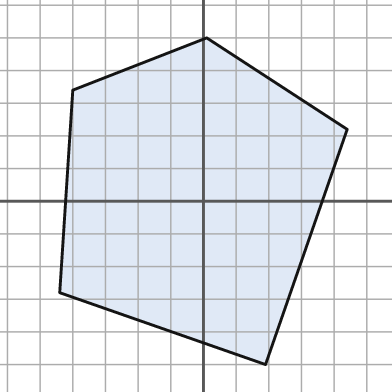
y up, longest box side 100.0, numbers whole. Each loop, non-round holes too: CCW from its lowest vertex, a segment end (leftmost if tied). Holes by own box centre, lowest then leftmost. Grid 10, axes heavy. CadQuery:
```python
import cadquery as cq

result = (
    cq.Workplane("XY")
    .moveTo(19.0, -50.0)
    .lineTo(44.0, 22.0)
    .lineTo(1.0, 50.0)
    .lineTo(-40.0, 34.0)
    .lineTo(-44.0, -28.0)
    .close()
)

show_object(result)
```